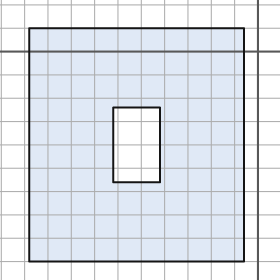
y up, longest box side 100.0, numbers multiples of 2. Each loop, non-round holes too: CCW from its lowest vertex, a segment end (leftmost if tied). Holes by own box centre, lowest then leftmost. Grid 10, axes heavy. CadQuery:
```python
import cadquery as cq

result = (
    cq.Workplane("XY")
    .moveTo(-98.0, -90.0)
    .lineTo(-6.0, -90.0)
    .lineTo(-6.0, 10.0)
    .lineTo(-98.0, 10.0)
    .close()
    .moveTo(-62.0, -56.0)
    .lineTo(-42.0, -56.0)
    .lineTo(-42.0, -24.0)
    .lineTo(-62.0, -24.0)
    .close()
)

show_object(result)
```